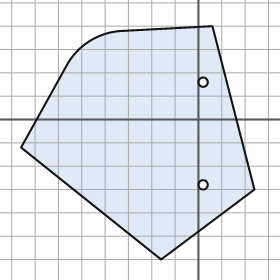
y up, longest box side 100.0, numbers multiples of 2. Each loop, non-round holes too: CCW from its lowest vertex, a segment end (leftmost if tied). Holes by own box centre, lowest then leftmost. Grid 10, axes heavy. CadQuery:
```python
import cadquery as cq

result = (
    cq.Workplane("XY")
    .moveTo(-16.0, -60.0)
    .lineTo(24.0, -30.0)
    .lineTo(6.0, 40.0)
    .lineTo(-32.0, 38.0)
    .threePointArc((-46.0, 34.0), (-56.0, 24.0))
    .lineTo(-76.0, -12.0)
    .close()
    .moveTo(2.0, -28.0)
    .circle(2.0)
    .moveTo(2.0, 16.0)
    .circle(2.0)
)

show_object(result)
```